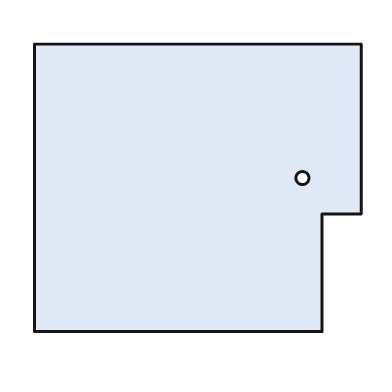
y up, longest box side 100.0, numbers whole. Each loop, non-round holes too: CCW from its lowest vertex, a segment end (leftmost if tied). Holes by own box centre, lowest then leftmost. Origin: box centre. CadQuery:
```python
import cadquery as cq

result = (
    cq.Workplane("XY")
    .moveTo(-50.0, -44.0)
    .lineTo(38.0, -44.0)
    .lineTo(38.0, -8.0)
    .lineTo(50.0, -8.0)
    .lineTo(50.0, 44.0)
    .lineTo(-50.0, 44.0)
    .close()
    .moveTo(32.0, 3.0)
    .circle(2.0)
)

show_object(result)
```